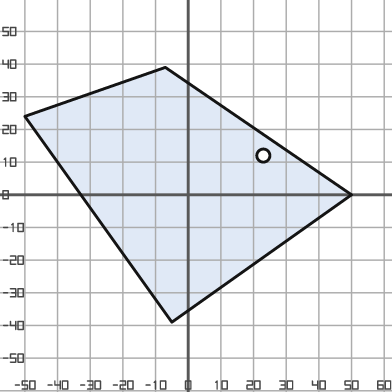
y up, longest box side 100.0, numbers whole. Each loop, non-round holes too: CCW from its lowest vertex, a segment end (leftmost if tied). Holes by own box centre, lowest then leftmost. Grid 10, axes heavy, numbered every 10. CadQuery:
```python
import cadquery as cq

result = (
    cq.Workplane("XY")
    .moveTo(-5.0, -39.0)
    .lineTo(50.0, 0.0)
    .lineTo(-7.0, 39.0)
    .lineTo(-50.0, 24.0)
    .close()
    .moveTo(23.0, 12.0)
    .circle(2.0)
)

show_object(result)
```